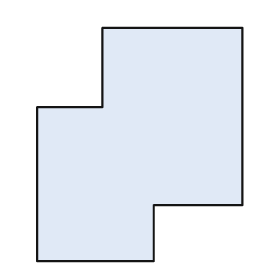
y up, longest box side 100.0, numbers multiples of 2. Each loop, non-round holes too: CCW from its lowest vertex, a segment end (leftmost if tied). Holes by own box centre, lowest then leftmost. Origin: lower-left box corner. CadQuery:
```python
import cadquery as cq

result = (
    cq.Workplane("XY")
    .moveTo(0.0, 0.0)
    .lineTo(50.0, 0.0)
    .lineTo(50.0, 24.0)
    .lineTo(88.0, 24.0)
    .lineTo(88.0, 100.0)
    .lineTo(28.0, 100.0)
    .lineTo(28.0, 66.0)
    .lineTo(0.0, 66.0)
    .close()
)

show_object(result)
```